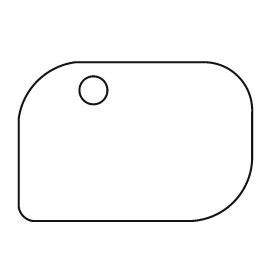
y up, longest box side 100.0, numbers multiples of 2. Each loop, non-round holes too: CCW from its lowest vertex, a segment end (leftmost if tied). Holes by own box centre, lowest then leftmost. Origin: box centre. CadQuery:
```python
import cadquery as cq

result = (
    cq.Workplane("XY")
    .moveTo(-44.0, -34.0)
    .lineTo(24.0, -34.0)
    .threePointArc((42.0, -26.0), (50.0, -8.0))
    .lineTo(50.0, 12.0)
    .threePointArc((44.0, 28.0), (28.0, 34.0))
    .lineTo(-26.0, 34.0)
    .threePointArc((-42.0, 26.0), (-50.0, 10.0))
    .lineTo(-50.0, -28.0)
    .threePointArc((-48.0, -32.0), (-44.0, -34.0))
    .close()
    .moveTo(-18.0, 22.0)
    .circle(6.0)
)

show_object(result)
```